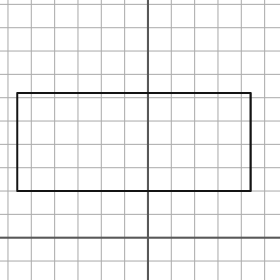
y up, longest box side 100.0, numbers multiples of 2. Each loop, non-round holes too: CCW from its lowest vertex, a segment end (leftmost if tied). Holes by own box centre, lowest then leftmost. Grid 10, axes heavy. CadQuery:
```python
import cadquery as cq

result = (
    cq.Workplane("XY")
    .moveTo(-56.0, 20.0)
    .lineTo(44.0, 20.0)
    .lineTo(44.0, 62.0)
    .lineTo(-56.0, 62.0)
    .close()
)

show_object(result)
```